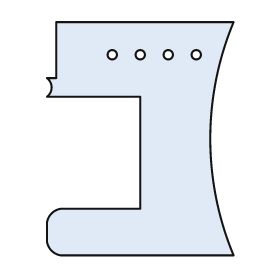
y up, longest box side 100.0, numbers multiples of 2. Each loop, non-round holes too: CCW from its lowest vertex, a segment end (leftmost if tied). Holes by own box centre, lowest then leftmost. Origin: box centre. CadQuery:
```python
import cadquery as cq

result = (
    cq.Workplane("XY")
    .moveTo(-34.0, -50.0)
    .lineTo(40.0, -50.0)
    .threePointArc((30.0, 0.0), (40.0, 50.0))
    .lineTo(-36.0, 50.0)
    .lineTo(-36.0, 26.0)
    .lineTo(-40.0, 26.0)
    .threePointArc((-38.0, 22.0), (-40.0, 18.0))
    .lineTo(0.0, 18.0)
    .lineTo(0.0, -30.0)
    .lineTo(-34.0, -30.0)
    .threePointArc((-38.0, -32.0), (-40.0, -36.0))
    .lineTo(-40.0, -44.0)
    .threePointArc((-38.0, -48.0), (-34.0, -50.0))
    .close()
    .moveTo(-12.0, 36.0)
    .circle(2.0)
    .moveTo(0.0, 36.0)
    .circle(2.0)
    .moveTo(12.0, 36.0)
    .circle(2.0)
    .moveTo(24.0, 36.0)
    .circle(2.0)
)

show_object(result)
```